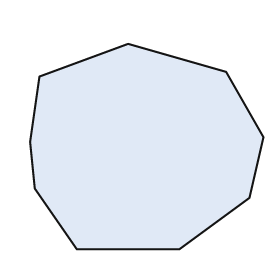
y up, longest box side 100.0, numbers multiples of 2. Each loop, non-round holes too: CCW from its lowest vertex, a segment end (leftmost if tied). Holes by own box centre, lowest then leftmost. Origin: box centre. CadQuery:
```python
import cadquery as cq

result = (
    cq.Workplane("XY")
    .moveTo(-30.0, -44.0)
    .lineTo(14.0, -44.0)
    .lineTo(44.0, -22.0)
    .lineTo(50.0, 4.0)
    .lineTo(34.0, 32.0)
    .lineTo(-8.0, 44.0)
    .lineTo(-46.0, 30.0)
    .lineTo(-50.0, 2.0)
    .lineTo(-48.0, -18.0)
    .close()
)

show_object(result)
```